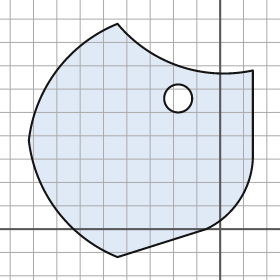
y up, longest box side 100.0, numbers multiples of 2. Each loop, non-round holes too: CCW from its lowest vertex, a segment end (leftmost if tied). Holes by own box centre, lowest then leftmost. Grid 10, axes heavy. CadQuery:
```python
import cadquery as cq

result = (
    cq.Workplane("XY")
    .moveTo(-44.0, -12.0)
    .lineTo(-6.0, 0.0)
    .threePointArc((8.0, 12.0), (14.0, 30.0))
    .lineTo(14.0, 68.0)
    .threePointArc((-18.0, 70.0), (-44.0, 88.0))
    .threePointArc((-70.0, 68.0), (-82.0, 38.0))
    .threePointArc((-70.0, 8.0), (-44.0, -12.0))
    .close()
    .moveTo(-18.0, 56.0)
    .circle(6.0)
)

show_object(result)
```